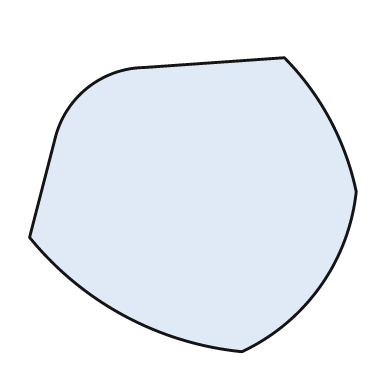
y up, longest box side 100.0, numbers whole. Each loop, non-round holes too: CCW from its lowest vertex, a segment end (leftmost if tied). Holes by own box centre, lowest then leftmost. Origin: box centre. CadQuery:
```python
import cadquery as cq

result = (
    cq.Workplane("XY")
    .moveTo(15.0, -45.0)
    .threePointArc((39.0, -25.0), (50.0, 4.0))
    .threePointArc((42.0, 26.0), (28.0, 45.0))
    .lineTo(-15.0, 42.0)
    .threePointArc((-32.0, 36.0), (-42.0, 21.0))
    .lineTo(-50.0, -10.0)
    .threePointArc((-21.0, -34.0), (15.0, -45.0))
    .close()
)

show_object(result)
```